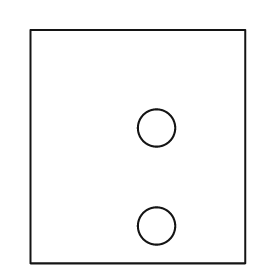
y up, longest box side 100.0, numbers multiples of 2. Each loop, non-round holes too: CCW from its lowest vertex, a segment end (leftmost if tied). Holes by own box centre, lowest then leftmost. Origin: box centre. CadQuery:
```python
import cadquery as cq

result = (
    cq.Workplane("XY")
    .moveTo(-46.0, -50.0)
    .lineTo(46.0, -50.0)
    .lineTo(46.0, 50.0)
    .lineTo(-46.0, 50.0)
    .close()
    .moveTo(8.0, -34.0)
    .circle(8.0)
    .moveTo(8.0, 8.0)
    .circle(8.0)
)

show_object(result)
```